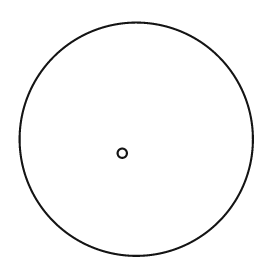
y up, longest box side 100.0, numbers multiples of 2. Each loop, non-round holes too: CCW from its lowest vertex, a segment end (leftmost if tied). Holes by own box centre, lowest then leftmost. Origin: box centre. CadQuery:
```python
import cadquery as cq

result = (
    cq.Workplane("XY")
    .moveTo(0.0, 0.0)
    .circle(50.0)
    .moveTo(-6.0, -6.0)
    .circle(2.0)
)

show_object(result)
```